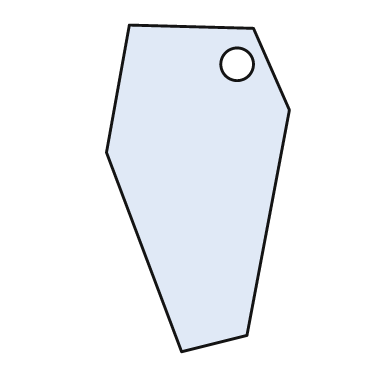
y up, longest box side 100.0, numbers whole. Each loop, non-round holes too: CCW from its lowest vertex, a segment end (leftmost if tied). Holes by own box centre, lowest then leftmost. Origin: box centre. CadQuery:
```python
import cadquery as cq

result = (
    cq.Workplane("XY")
    .moveTo(-5.0, -50.0)
    .lineTo(15.0, -45.0)
    .lineTo(28.0, 24.0)
    .lineTo(17.0, 49.0)
    .lineTo(-21.0, 50.0)
    .lineTo(-28.0, 11.0)
    .close()
    .moveTo(12.0, 38.0)
    .circle(5.0)
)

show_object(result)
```